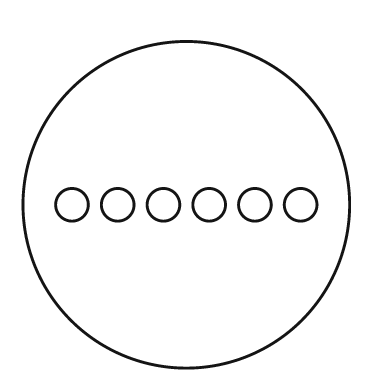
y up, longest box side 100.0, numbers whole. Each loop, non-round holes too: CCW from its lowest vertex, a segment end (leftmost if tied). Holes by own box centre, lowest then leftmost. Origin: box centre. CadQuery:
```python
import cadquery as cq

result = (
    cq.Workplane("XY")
    .moveTo(0.0, 0.0)
    .circle(50.0)
    .moveTo(-35.0, 0.0)
    .circle(5.0)
    .moveTo(-21.0, 0.0)
    .circle(5.0)
    .moveTo(-7.0, 0.0)
    .circle(5.0)
    .moveTo(7.0, 0.0)
    .circle(5.0)
    .moveTo(21.0, 0.0)
    .circle(5.0)
    .moveTo(35.0, 0.0)
    .circle(5.0)
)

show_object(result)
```